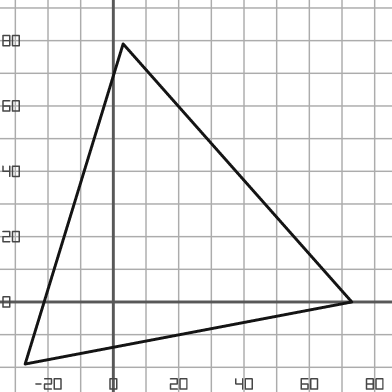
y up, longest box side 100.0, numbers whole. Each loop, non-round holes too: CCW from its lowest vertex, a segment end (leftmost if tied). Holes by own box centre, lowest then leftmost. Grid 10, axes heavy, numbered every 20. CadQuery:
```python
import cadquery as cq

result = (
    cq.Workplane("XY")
    .moveTo(-27.0, -19.0)
    .lineTo(73.0, 0.0)
    .lineTo(3.0, 79.0)
    .close()
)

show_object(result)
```